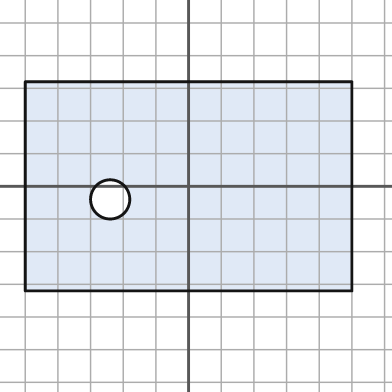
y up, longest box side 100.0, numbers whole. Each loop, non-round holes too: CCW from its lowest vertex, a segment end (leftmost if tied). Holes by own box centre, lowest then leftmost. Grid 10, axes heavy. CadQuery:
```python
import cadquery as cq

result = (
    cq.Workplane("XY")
    .moveTo(-50.0, -32.0)
    .lineTo(50.0, -32.0)
    .lineTo(50.0, 32.0)
    .lineTo(-50.0, 32.0)
    .close()
    .moveTo(-24.0, -4.0)
    .circle(6.0)
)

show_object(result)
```